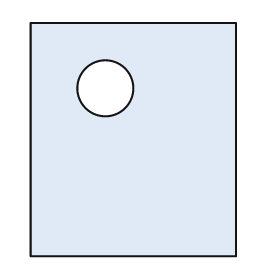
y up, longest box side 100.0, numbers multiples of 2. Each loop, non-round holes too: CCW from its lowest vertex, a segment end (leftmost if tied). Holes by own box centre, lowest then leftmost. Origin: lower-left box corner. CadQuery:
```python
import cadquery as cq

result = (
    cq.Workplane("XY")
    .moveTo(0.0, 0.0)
    .lineTo(88.0, 0.0)
    .lineTo(88.0, 100.0)
    .lineTo(0.0, 100.0)
    .close()
    .moveTo(32.0, 72.0)
    .circle(12.0)
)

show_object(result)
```